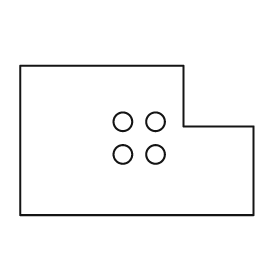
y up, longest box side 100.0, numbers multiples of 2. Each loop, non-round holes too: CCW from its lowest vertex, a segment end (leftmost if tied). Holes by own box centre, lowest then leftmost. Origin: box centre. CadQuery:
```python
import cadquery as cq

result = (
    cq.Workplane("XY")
    .moveTo(-50.0, -32.0)
    .lineTo(50.0, -32.0)
    .lineTo(50.0, 6.0)
    .lineTo(20.0, 6.0)
    .lineTo(20.0, 32.0)
    .lineTo(-50.0, 32.0)
    .close()
    .moveTo(-6.0, -6.0)
    .circle(4.0)
    .moveTo(8.0, -6.0)
    .circle(4.0)
    .moveTo(-6.0, 8.0)
    .circle(4.0)
    .moveTo(8.0, 8.0)
    .circle(4.0)
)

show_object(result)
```